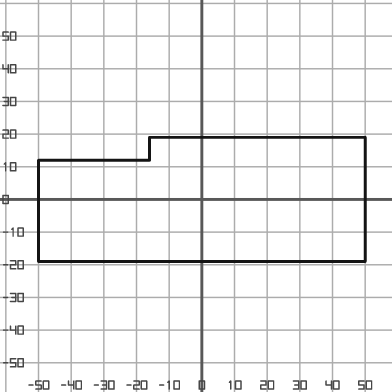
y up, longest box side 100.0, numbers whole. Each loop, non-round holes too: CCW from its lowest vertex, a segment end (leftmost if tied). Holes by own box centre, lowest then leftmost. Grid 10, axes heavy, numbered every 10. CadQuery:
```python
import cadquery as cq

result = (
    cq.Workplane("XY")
    .moveTo(-50.0, -19.0)
    .lineTo(50.0, -19.0)
    .lineTo(50.0, 19.0)
    .lineTo(-16.0, 19.0)
    .lineTo(-16.0, 12.0)
    .lineTo(-50.0, 12.0)
    .close()
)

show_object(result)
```